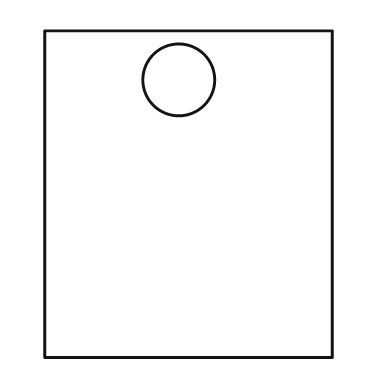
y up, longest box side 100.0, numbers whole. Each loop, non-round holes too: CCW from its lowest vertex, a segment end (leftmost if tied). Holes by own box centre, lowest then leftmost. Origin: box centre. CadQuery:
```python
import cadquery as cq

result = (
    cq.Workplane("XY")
    .moveTo(-44.0, -50.0)
    .lineTo(44.0, -50.0)
    .lineTo(44.0, 50.0)
    .lineTo(-44.0, 50.0)
    .close()
    .moveTo(-3.0, 35.0)
    .circle(11.0)
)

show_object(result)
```